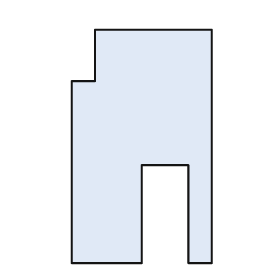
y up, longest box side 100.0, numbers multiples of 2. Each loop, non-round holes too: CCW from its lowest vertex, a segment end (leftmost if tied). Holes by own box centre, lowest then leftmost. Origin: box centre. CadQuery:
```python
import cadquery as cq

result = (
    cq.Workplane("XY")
    .moveTo(-30.0, -50.0)
    .lineTo(0.0, -50.0)
    .lineTo(0.0, -8.0)
    .lineTo(20.0, -8.0)
    .lineTo(20.0, -50.0)
    .lineTo(30.0, -50.0)
    .lineTo(30.0, 50.0)
    .lineTo(-20.0, 50.0)
    .lineTo(-20.0, 28.0)
    .lineTo(-30.0, 28.0)
    .close()
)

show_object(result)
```